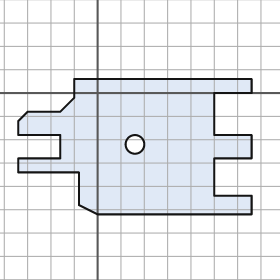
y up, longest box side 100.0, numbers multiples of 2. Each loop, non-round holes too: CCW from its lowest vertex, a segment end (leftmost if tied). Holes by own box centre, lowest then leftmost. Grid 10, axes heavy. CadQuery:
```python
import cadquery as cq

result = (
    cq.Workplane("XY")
    .moveTo(0.0, -52.0)
    .lineTo(66.0, -52.0)
    .lineTo(66.0, -44.0)
    .lineTo(50.0, -44.0)
    .lineTo(50.0, -28.0)
    .lineTo(66.0, -28.0)
    .lineTo(66.0, -18.0)
    .lineTo(50.0, -18.0)
    .lineTo(50.0, 0.0)
    .lineTo(66.0, 0.0)
    .lineTo(66.0, 6.0)
    .lineTo(-10.0, 6.0)
    .lineTo(-10.0, -2.0)
    .lineTo(-16.0, -8.0)
    .lineTo(-30.0, -8.0)
    .lineTo(-34.0, -12.0)
    .lineTo(-34.0, -18.0)
    .lineTo(-16.0, -18.0)
    .lineTo(-16.0, -28.0)
    .lineTo(-34.0, -28.0)
    .lineTo(-34.0, -34.0)
    .lineTo(-8.0, -34.0)
    .lineTo(-8.0, -48.0)
    .close()
    .moveTo(16.0, -22.0)
    .circle(4.0)
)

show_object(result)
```